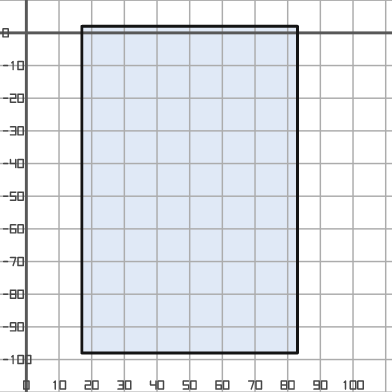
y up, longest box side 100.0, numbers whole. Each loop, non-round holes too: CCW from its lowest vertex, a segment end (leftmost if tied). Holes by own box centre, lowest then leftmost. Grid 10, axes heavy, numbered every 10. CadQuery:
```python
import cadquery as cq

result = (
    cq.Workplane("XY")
    .moveTo(17.0, -98.0)
    .lineTo(83.0, -98.0)
    .lineTo(83.0, 2.0)
    .lineTo(17.0, 2.0)
    .close()
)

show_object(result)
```